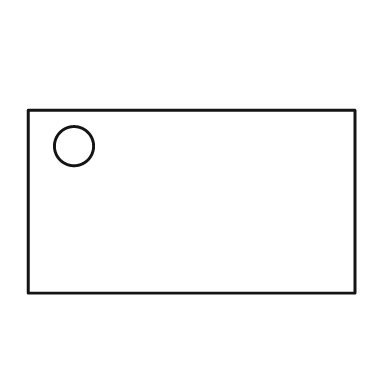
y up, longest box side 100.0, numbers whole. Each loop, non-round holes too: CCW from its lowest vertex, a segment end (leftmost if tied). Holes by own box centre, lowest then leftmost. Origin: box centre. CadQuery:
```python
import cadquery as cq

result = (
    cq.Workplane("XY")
    .moveTo(-50.0, -28.0)
    .lineTo(50.0, -28.0)
    .lineTo(50.0, 28.0)
    .lineTo(-50.0, 28.0)
    .close()
    .moveTo(-36.0, 17.0)
    .circle(6.0)
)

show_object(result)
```